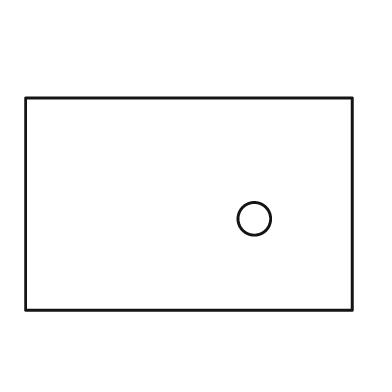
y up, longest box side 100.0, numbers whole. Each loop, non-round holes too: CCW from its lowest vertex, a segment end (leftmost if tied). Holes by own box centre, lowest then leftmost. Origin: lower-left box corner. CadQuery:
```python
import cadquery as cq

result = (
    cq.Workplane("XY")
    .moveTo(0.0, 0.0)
    .lineTo(100.0, 0.0)
    .lineTo(100.0, 65.0)
    .lineTo(0.0, 65.0)
    .close()
    .moveTo(70.0, 28.0)
    .circle(5.0)
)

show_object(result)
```